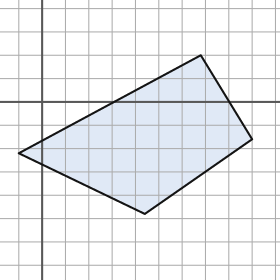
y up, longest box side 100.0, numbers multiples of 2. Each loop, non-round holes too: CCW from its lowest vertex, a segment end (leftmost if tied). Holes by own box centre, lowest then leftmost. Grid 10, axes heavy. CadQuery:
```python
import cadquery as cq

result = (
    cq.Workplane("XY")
    .moveTo(44.0, -48.0)
    .lineTo(90.0, -16.0)
    .lineTo(68.0, 20.0)
    .lineTo(-10.0, -22.0)
    .close()
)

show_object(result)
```